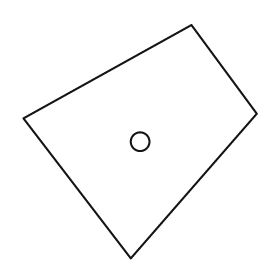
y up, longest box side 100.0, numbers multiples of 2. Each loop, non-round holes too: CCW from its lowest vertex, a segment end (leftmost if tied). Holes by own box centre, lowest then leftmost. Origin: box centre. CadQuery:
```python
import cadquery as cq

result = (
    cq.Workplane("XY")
    .moveTo(-4.0, -50.0)
    .lineTo(50.0, 12.0)
    .lineTo(22.0, 50.0)
    .lineTo(-50.0, 10.0)
    .close()
    .moveTo(0.0, 0.0)
    .circle(4.0)
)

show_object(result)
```